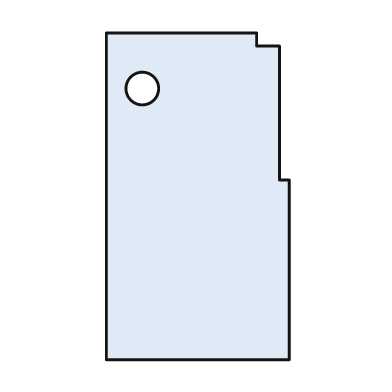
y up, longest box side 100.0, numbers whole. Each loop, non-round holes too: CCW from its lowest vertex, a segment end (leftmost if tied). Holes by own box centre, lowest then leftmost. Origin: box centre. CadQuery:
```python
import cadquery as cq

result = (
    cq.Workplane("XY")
    .moveTo(-28.0, -50.0)
    .lineTo(28.0, -50.0)
    .lineTo(28.0, 5.0)
    .lineTo(25.0, 5.0)
    .lineTo(25.0, 46.0)
    .lineTo(18.0, 46.0)
    .lineTo(18.0, 50.0)
    .lineTo(-28.0, 50.0)
    .close()
    .moveTo(-17.0, 33.0)
    .circle(5.0)
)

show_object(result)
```